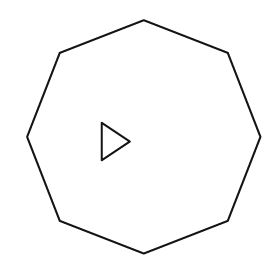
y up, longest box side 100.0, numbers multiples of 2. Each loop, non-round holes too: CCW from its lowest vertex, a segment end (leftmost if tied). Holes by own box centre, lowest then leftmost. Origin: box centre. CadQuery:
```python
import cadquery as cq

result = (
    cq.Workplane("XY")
    .moveTo(0.0, -50.0)
    .lineTo(36.0, -36.0)
    .lineTo(50.0, 0.0)
    .lineTo(36.0, 36.0)
    .lineTo(0.0, 50.0)
    .lineTo(-36.0, 36.0)
    .lineTo(-50.0, 0.0)
    .lineTo(-36.0, -36.0)
    .close()
    .moveTo(-18.0, -10.0)
    .lineTo(-6.0, -2.0)
    .lineTo(-18.0, 6.0)
    .close()
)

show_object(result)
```